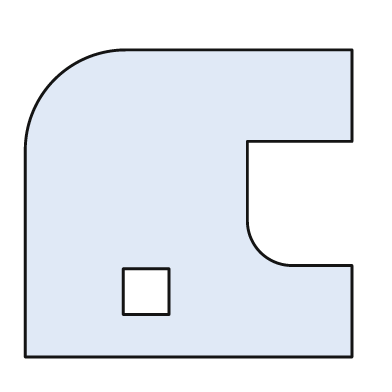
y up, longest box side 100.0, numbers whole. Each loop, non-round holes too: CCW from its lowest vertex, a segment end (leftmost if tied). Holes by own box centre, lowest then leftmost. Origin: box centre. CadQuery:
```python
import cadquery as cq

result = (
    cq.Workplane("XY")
    .moveTo(-50.0, -47.0)
    .lineTo(50.0, -47.0)
    .lineTo(50.0, -19.0)
    .lineTo(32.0, -19.0)
    .threePointArc((22.0, -15.0), (18.0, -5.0))
    .lineTo(18.0, 19.0)
    .lineTo(50.0, 19.0)
    .lineTo(50.0, 47.0)
    .lineTo(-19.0, 47.0)
    .threePointArc((-41.0, 38.0), (-50.0, 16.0))
    .close()
    .moveTo(-20.0, -34.0)
    .lineTo(-6.0, -34.0)
    .lineTo(-6.0, -20.0)
    .lineTo(-20.0, -20.0)
    .close()
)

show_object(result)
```